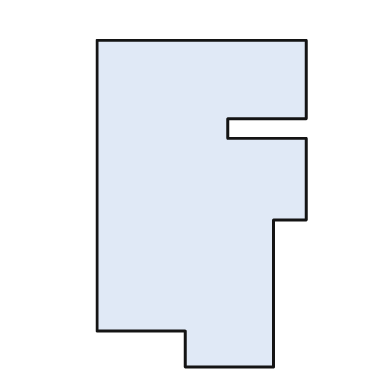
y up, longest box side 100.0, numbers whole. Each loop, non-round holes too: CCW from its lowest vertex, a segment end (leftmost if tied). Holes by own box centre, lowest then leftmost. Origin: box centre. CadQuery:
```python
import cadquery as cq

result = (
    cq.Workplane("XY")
    .moveTo(-5.0, -50.0)
    .lineTo(22.0, -50.0)
    .lineTo(22.0, -5.0)
    .lineTo(32.0, -5.0)
    .lineTo(32.0, 20.0)
    .lineTo(8.0, 20.0)
    .lineTo(8.0, 26.0)
    .lineTo(32.0, 26.0)
    .lineTo(32.0, 50.0)
    .lineTo(-32.0, 50.0)
    .lineTo(-32.0, -39.0)
    .lineTo(-5.0, -39.0)
    .close()
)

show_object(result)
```